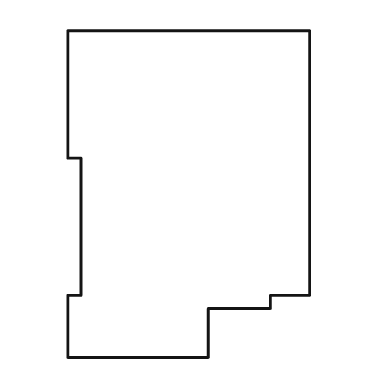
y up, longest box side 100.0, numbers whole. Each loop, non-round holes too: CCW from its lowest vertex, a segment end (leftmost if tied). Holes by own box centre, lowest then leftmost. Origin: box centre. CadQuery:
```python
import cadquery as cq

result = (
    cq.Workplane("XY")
    .moveTo(-37.0, -50.0)
    .lineTo(6.0, -50.0)
    .lineTo(6.0, -35.0)
    .lineTo(25.0, -35.0)
    .lineTo(25.0, -31.0)
    .lineTo(37.0, -31.0)
    .lineTo(37.0, 50.0)
    .lineTo(-37.0, 50.0)
    .lineTo(-37.0, 11.0)
    .lineTo(-33.0, 11.0)
    .lineTo(-33.0, -31.0)
    .lineTo(-37.0, -31.0)
    .close()
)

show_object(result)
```